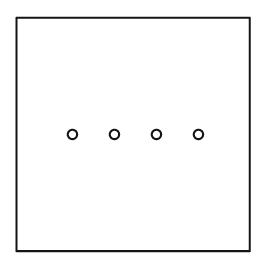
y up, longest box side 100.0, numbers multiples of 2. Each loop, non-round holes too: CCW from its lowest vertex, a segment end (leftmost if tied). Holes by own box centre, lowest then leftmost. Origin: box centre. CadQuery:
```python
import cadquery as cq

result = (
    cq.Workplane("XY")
    .moveTo(-50.0, -50.0)
    .lineTo(50.0, -50.0)
    .lineTo(50.0, 50.0)
    .lineTo(-50.0, 50.0)
    .close()
    .moveTo(-26.0, 0.0)
    .circle(2.0)
    .moveTo(-8.0, 0.0)
    .circle(2.0)
    .moveTo(10.0, 0.0)
    .circle(2.0)
    .moveTo(28.0, 0.0)
    .circle(2.0)
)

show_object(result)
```